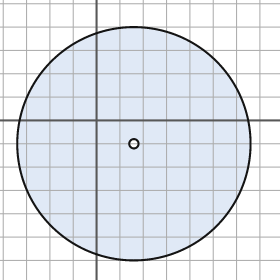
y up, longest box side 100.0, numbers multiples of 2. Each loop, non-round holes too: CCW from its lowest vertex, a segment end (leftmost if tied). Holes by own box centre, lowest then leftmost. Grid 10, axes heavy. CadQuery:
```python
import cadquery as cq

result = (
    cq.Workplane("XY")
    .moveTo(16.0, -10.0)
    .circle(50.0)
    .moveTo(16.0, -10.0)
    .circle(2.0)
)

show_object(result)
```